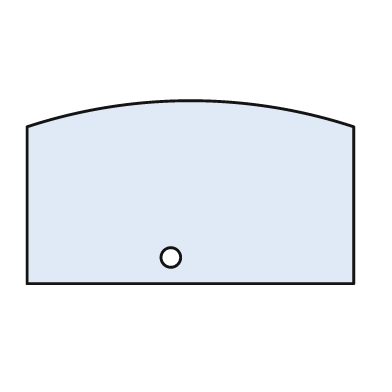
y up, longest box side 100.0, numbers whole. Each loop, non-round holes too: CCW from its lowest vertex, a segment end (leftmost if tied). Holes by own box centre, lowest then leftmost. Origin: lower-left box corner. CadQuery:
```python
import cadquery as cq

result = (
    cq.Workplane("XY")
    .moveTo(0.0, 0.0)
    .lineTo(100.0, 0.0)
    .lineTo(100.0, 48.0)
    .threePointArc((50.0, 56.0), (0.0, 48.0))
    .close()
    .moveTo(44.0, 8.0)
    .circle(3.0)
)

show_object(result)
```